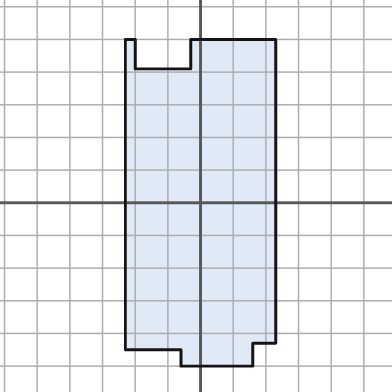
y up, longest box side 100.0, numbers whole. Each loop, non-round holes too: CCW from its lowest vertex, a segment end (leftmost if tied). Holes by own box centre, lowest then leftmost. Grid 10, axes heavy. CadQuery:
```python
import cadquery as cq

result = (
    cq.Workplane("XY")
    .moveTo(-6.0, -50.0)
    .lineTo(16.0, -50.0)
    .lineTo(16.0, -43.0)
    .lineTo(23.0, -43.0)
    .lineTo(23.0, 50.0)
    .lineTo(-3.0, 50.0)
    .lineTo(-3.0, 41.0)
    .lineTo(-20.0, 41.0)
    .lineTo(-20.0, 50.0)
    .lineTo(-23.0, 50.0)
    .lineTo(-23.0, -45.0)
    .lineTo(-6.0, -45.0)
    .close()
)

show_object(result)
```